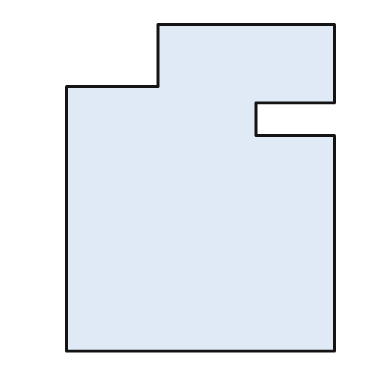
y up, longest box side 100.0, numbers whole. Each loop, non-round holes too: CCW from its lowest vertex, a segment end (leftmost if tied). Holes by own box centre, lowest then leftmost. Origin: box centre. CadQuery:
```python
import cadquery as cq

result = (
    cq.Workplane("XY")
    .moveTo(-41.0, -50.0)
    .lineTo(41.0, -50.0)
    .lineTo(41.0, 16.0)
    .lineTo(17.0, 16.0)
    .lineTo(17.0, 26.0)
    .lineTo(41.0, 26.0)
    .lineTo(41.0, 50.0)
    .lineTo(-13.0, 50.0)
    .lineTo(-13.0, 31.0)
    .lineTo(-41.0, 31.0)
    .close()
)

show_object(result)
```